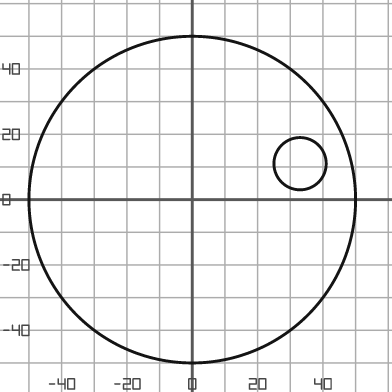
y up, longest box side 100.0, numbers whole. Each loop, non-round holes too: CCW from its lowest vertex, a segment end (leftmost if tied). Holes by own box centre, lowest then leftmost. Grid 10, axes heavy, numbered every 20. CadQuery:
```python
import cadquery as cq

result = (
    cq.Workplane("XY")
    .moveTo(0.0, 0.0)
    .circle(50.0)
    .moveTo(33.0, 11.0)
    .circle(8.0)
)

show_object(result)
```